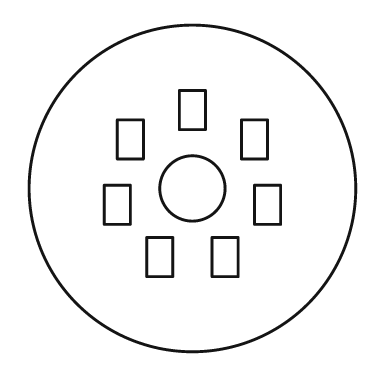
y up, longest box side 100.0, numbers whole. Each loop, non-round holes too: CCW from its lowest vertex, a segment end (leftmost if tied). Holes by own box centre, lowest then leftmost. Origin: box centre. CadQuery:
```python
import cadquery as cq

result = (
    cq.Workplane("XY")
    .moveTo(0.0, 0.0)
    .circle(50.0)
    .moveTo(-14.0, -27.0)
    .lineTo(-6.0, -27.0)
    .lineTo(-6.0, -15.0)
    .lineTo(-14.0, -15.0)
    .close()
    .moveTo(6.0, -27.0)
    .lineTo(14.0, -27.0)
    .lineTo(14.0, -15.0)
    .lineTo(6.0, -15.0)
    .close()
    .moveTo(-27.0, -11.0)
    .lineTo(-19.0, -11.0)
    .lineTo(-19.0, 1.0)
    .lineTo(-27.0, 1.0)
    .close()
    .moveTo(19.0, -11.0)
    .lineTo(27.0, -11.0)
    .lineTo(27.0, 1.0)
    .lineTo(19.0, 1.0)
    .close()
    .moveTo(0.0, 0.0)
    .circle(10.0)
    .moveTo(-23.0, 9.0)
    .lineTo(-15.0, 9.0)
    .lineTo(-15.0, 21.0)
    .lineTo(-23.0, 21.0)
    .close()
    .moveTo(15.0, 9.0)
    .lineTo(23.0, 9.0)
    .lineTo(23.0, 21.0)
    .lineTo(15.0, 21.0)
    .close()
    .moveTo(-4.0, 18.0)
    .lineTo(4.0, 18.0)
    .lineTo(4.0, 30.0)
    .lineTo(-4.0, 30.0)
    .close()
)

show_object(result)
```